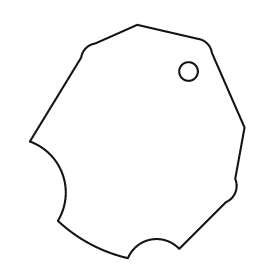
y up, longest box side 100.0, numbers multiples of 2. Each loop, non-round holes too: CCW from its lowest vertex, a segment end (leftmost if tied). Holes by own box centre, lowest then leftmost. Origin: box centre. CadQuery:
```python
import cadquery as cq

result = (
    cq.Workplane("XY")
    .moveTo(-4.0, -50.0)
    .threePointArc((6.0, -42.0), (18.0, -46.0))
    .lineTo(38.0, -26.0)
    .threePointArc((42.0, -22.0), (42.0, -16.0))
    .lineTo(46.0, 6.0)
    .lineTo(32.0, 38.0)
    .threePointArc((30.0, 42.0), (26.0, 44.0))
    .lineTo(0.0, 50.0)
    .lineTo(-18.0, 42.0)
    .threePointArc((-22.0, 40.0), (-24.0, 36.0))
    .lineTo(-46.0, 0.0)
    .threePointArc((-32.0, -14.0), (-34.0, -34.0))
    .threePointArc((-20.0, -44.0), (-4.0, -50.0))
    .close()
    .moveTo(22.0, 30.0)
    .circle(4.0)
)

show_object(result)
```